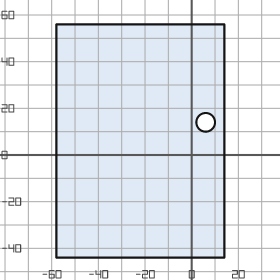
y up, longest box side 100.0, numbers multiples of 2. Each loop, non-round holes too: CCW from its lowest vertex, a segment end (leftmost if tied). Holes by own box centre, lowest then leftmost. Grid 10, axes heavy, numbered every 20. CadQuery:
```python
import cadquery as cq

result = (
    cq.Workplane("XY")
    .moveTo(-58.0, -44.0)
    .lineTo(14.0, -44.0)
    .lineTo(14.0, 56.0)
    .lineTo(-58.0, 56.0)
    .close()
    .moveTo(6.0, 14.0)
    .circle(4.0)
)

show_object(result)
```